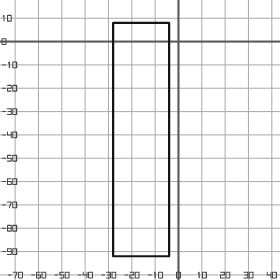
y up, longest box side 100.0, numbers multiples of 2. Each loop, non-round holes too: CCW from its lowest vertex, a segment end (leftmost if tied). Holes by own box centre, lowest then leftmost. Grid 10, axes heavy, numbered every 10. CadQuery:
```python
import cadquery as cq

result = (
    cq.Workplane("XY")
    .moveTo(-28.0, -92.0)
    .lineTo(-4.0, -92.0)
    .lineTo(-4.0, 8.0)
    .lineTo(-28.0, 8.0)
    .close()
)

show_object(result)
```